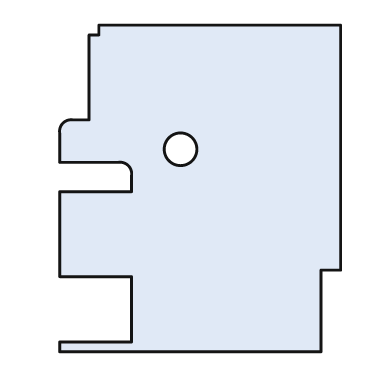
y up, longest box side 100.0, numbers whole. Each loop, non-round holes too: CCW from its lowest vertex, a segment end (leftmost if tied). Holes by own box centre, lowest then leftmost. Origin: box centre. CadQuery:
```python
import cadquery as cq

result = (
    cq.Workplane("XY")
    .moveTo(-43.0, -50.0)
    .lineTo(37.0, -50.0)
    .lineTo(37.0, -25.0)
    .lineTo(43.0, -25.0)
    .lineTo(43.0, 50.0)
    .lineTo(-31.0, 50.0)
    .lineTo(-31.0, 47.0)
    .lineTo(-34.0, 47.0)
    .lineTo(-34.0, 21.0)
    .lineTo(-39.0, 21.0)
    .threePointArc((-42.0, 20.0), (-43.0, 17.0))
    .lineTo(-43.0, 8.0)
    .lineTo(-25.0, 8.0)
    .threePointArc((-22.0, 7.0), (-21.0, 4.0))
    .lineTo(-21.0, -1.0)
    .lineTo(-43.0, -1.0)
    .lineTo(-43.0, -27.0)
    .lineTo(-21.0, -27.0)
    .lineTo(-21.0, -47.0)
    .lineTo(-43.0, -47.0)
    .close()
    .moveTo(-6.0, 12.0)
    .circle(5.0)
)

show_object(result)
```